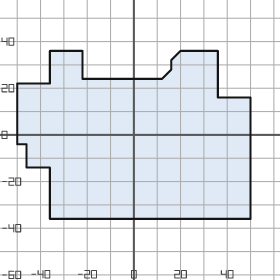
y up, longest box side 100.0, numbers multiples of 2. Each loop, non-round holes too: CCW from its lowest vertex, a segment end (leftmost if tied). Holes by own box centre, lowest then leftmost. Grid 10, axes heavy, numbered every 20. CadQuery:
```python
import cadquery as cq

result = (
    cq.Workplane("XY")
    .moveTo(-36.0, -36.0)
    .lineTo(50.0, -36.0)
    .lineTo(50.0, 16.0)
    .lineTo(36.0, 16.0)
    .lineTo(36.0, 36.0)
    .lineTo(20.0, 36.0)
    .lineTo(16.0, 32.0)
    .lineTo(16.0, 28.0)
    .lineTo(12.0, 24.0)
    .lineTo(-22.0, 24.0)
    .lineTo(-22.0, 36.0)
    .lineTo(-36.0, 36.0)
    .lineTo(-36.0, 22.0)
    .lineTo(-50.0, 22.0)
    .lineTo(-50.0, -4.0)
    .lineTo(-46.0, -4.0)
    .lineTo(-46.0, -14.0)
    .lineTo(-36.0, -14.0)
    .close()
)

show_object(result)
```